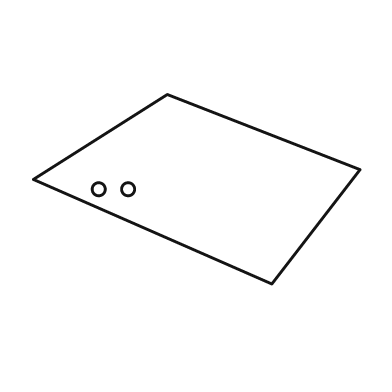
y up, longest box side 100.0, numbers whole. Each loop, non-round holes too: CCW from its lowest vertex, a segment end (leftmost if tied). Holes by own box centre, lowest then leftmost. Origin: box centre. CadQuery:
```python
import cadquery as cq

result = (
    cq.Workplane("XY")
    .moveTo(23.0, -29.0)
    .lineTo(50.0, 6.0)
    .lineTo(-9.0, 29.0)
    .lineTo(-50.0, 3.0)
    .close()
    .moveTo(-30.0, 0.0)
    .circle(2.0)
    .moveTo(-21.0, 0.0)
    .circle(2.0)
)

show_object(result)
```